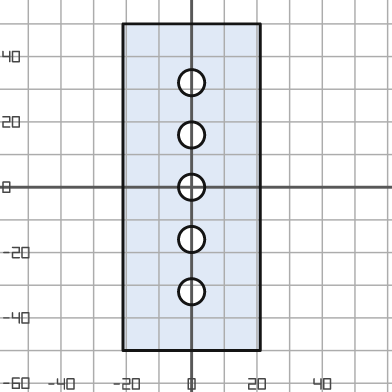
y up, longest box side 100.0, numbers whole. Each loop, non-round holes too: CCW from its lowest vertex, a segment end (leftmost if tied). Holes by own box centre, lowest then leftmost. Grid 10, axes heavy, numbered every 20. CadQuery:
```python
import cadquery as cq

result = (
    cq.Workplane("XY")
    .moveTo(-21.0, -50.0)
    .lineTo(21.0, -50.0)
    .lineTo(21.0, 50.0)
    .lineTo(-21.0, 50.0)
    .close()
    .moveTo(0.0, -32.0)
    .circle(4.0)
    .moveTo(0.0, -16.0)
    .circle(4.0)
    .moveTo(0.0, 0.0)
    .circle(4.0)
    .moveTo(0.0, 16.0)
    .circle(4.0)
    .moveTo(0.0, 32.0)
    .circle(4.0)
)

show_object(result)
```